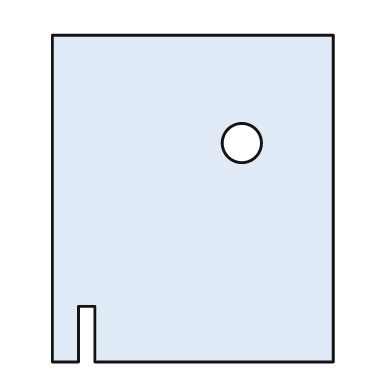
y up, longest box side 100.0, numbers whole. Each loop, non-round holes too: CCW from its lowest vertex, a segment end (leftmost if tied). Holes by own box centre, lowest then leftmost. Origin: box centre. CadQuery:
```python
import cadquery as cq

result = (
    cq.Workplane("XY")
    .moveTo(-43.0, -50.0)
    .lineTo(-35.0, -50.0)
    .lineTo(-35.0, -33.0)
    .lineTo(-30.0, -33.0)
    .lineTo(-30.0, -50.0)
    .lineTo(43.0, -50.0)
    .lineTo(43.0, 50.0)
    .lineTo(-43.0, 50.0)
    .close()
    .moveTo(15.0, 17.0)
    .circle(6.0)
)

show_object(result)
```